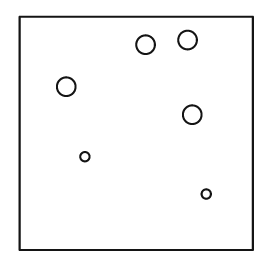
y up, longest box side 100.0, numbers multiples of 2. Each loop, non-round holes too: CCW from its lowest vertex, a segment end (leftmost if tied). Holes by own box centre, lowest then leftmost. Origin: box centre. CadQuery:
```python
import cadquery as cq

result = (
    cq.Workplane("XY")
    .moveTo(-50.0, -50.0)
    .lineTo(50.0, -50.0)
    .lineTo(50.0, 50.0)
    .lineTo(-50.0, 50.0)
    .close()
    .moveTo(30.0, -26.0)
    .circle(2.0)
    .moveTo(-22.0, -10.0)
    .circle(2.0)
    .moveTo(24.0, 8.0)
    .circle(4.0)
    .moveTo(-30.0, 20.0)
    .circle(4.0)
    .moveTo(4.0, 38.0)
    .circle(4.0)
    .moveTo(22.0, 40.0)
    .circle(4.0)
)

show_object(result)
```